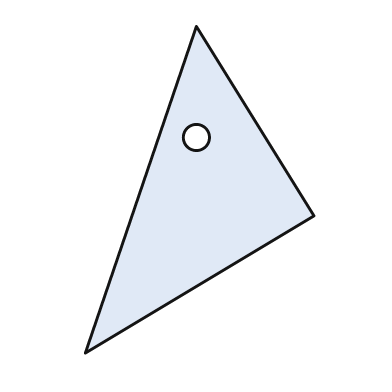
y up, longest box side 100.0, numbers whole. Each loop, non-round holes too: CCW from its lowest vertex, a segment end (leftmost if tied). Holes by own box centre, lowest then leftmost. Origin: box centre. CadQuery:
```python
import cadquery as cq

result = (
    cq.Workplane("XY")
    .moveTo(-35.0, -50.0)
    .lineTo(35.0, -8.0)
    .lineTo(-1.0, 50.0)
    .close()
    .moveTo(-1.0, 16.0)
    .circle(4.0)
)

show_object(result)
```